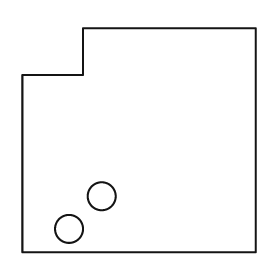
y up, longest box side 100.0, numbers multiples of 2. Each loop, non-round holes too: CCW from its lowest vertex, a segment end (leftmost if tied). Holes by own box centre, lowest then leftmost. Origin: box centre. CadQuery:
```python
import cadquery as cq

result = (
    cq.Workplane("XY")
    .moveTo(-50.0, -48.0)
    .lineTo(50.0, -48.0)
    .lineTo(50.0, 48.0)
    .lineTo(-24.0, 48.0)
    .lineTo(-24.0, 28.0)
    .lineTo(-50.0, 28.0)
    .close()
    .moveTo(-30.0, -38.0)
    .circle(6.0)
    .moveTo(-16.0, -24.0)
    .circle(6.0)
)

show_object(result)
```